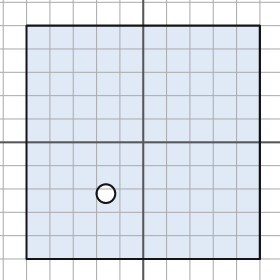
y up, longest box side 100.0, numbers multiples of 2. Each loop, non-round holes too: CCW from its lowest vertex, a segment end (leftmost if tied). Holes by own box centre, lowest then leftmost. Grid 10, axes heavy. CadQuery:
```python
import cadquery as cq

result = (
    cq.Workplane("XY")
    .moveTo(-50.0, -50.0)
    .lineTo(50.0, -50.0)
    .lineTo(50.0, 50.0)
    .lineTo(-50.0, 50.0)
    .close()
    .moveTo(-16.0, -22.0)
    .circle(4.0)
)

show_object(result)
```